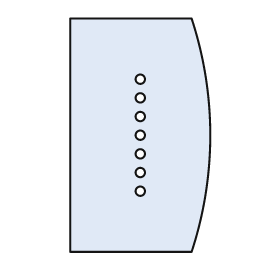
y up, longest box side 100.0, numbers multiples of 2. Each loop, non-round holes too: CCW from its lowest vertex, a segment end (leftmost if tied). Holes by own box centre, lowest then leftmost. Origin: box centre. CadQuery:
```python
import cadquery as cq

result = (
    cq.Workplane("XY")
    .moveTo(-30.0, -50.0)
    .lineTo(22.0, -50.0)
    .threePointArc((30.0, 0.0), (22.0, 50.0))
    .lineTo(-30.0, 50.0)
    .close()
    .moveTo(0.0, -24.0)
    .circle(2.0)
    .moveTo(0.0, -16.0)
    .circle(2.0)
    .moveTo(0.0, -8.0)
    .circle(2.0)
    .moveTo(0.0, 0.0)
    .circle(2.0)
    .moveTo(0.0, 8.0)
    .circle(2.0)
    .moveTo(0.0, 16.0)
    .circle(2.0)
    .moveTo(0.0, 24.0)
    .circle(2.0)
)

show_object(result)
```